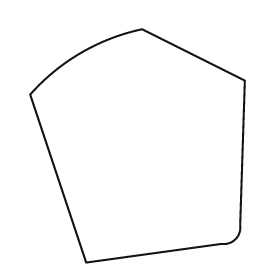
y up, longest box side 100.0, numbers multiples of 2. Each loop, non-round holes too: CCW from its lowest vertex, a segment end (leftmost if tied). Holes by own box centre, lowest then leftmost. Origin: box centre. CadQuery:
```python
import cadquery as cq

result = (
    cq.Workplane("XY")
    .moveTo(-22.0, -50.0)
    .lineTo(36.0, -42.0)
    .threePointArc((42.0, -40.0), (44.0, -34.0))
    .lineTo(46.0, 28.0)
    .lineTo(2.0, 50.0)
    .threePointArc((-24.0, 40.0), (-46.0, 22.0))
    .close()
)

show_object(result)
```